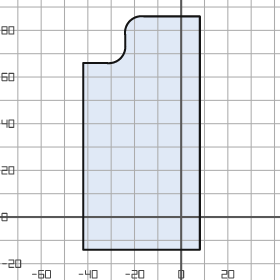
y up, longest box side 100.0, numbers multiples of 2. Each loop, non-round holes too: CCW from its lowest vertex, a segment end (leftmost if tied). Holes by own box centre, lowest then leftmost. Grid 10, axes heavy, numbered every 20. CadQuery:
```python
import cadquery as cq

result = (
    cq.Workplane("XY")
    .moveTo(-42.0, -14.0)
    .lineTo(8.0, -14.0)
    .lineTo(8.0, 86.0)
    .lineTo(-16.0, 86.0)
    .threePointArc((-22.0, 84.0), (-24.0, 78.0))
    .lineTo(-24.0, 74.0)
    .threePointArc((-26.0, 68.0), (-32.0, 66.0))
    .lineTo(-42.0, 66.0)
    .close()
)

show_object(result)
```